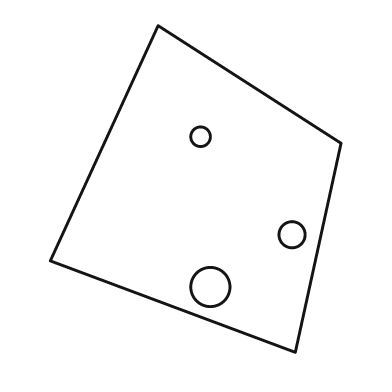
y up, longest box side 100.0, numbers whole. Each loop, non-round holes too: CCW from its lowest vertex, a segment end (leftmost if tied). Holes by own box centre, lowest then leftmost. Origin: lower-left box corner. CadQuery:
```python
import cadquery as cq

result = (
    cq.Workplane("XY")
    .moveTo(75.0, 0.0)
    .lineTo(89.0, 64.0)
    .lineTo(33.0, 100.0)
    .lineTo(0.0, 28.0)
    .close()
    .moveTo(49.0, 20.0)
    .circle(6.0)
    .moveTo(74.0, 36.0)
    .circle(4.0)
    .moveTo(46.0, 66.0)
    .circle(3.0)
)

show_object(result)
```